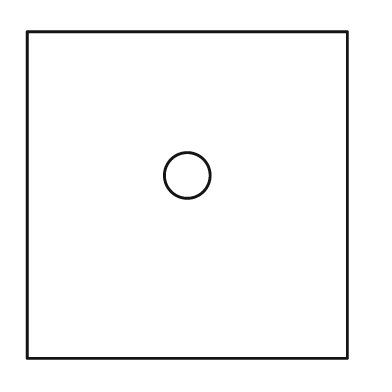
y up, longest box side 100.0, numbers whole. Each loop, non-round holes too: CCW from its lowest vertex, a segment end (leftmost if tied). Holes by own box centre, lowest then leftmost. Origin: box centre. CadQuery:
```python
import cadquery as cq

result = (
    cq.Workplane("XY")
    .moveTo(-49.0, -50.0)
    .lineTo(49.0, -50.0)
    .lineTo(49.0, 50.0)
    .lineTo(-49.0, 50.0)
    .close()
    .moveTo(0.0, 6.0)
    .circle(7.0)
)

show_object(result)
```